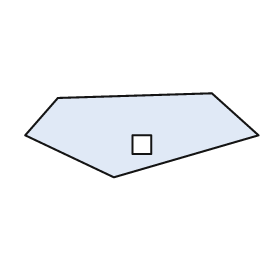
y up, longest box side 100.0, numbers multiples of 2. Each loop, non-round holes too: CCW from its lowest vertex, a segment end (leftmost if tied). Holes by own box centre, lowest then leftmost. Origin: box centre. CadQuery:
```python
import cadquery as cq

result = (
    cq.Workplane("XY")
    .moveTo(-12.0, -18.0)
    .lineTo(50.0, 0.0)
    .lineTo(30.0, 18.0)
    .lineTo(-36.0, 16.0)
    .lineTo(-50.0, 0.0)
    .close()
    .moveTo(-4.0, -8.0)
    .lineTo(4.0, -8.0)
    .lineTo(4.0, 0.0)
    .lineTo(-4.0, 0.0)
    .close()
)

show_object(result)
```